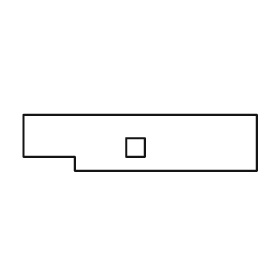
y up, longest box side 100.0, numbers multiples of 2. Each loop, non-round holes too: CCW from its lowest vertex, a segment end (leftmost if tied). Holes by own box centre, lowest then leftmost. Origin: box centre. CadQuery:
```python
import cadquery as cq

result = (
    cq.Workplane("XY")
    .moveTo(-28.0, -12.0)
    .lineTo(50.0, -12.0)
    .lineTo(50.0, 12.0)
    .lineTo(-50.0, 12.0)
    .lineTo(-50.0, -6.0)
    .lineTo(-28.0, -6.0)
    .close()
    .moveTo(-6.0, -6.0)
    .lineTo(2.0, -6.0)
    .lineTo(2.0, 2.0)
    .lineTo(-6.0, 2.0)
    .close()
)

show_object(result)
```